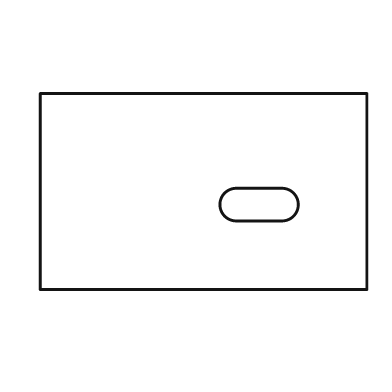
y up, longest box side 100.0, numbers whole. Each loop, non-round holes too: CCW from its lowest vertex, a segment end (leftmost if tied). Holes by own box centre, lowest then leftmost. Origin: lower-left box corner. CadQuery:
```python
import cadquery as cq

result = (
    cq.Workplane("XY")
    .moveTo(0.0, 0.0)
    .lineTo(100.0, 0.0)
    .lineTo(100.0, 60.0)
    .lineTo(0.0, 60.0)
    .close()
    .moveTo(60.0, 21.0)
    .lineTo(74.0, 21.0)
    .threePointArc((79.0, 26.0), (74.0, 31.0))
    .lineTo(60.0, 31.0)
    .threePointArc((55.0, 26.0), (60.0, 21.0))
    .close()
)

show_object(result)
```